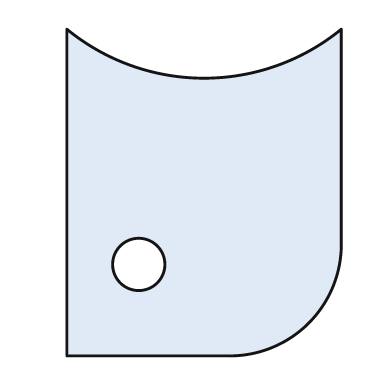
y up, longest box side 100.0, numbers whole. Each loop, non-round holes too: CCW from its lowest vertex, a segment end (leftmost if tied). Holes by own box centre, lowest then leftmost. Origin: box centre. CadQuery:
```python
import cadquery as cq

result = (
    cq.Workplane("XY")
    .moveTo(-42.0, -50.0)
    .lineTo(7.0, -50.0)
    .threePointArc((32.0, -40.0), (42.0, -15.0))
    .lineTo(42.0, 50.0)
    .threePointArc((0.0, 35.0), (-42.0, 50.0))
    .close()
    .moveTo(-20.0, -22.0)
    .circle(8.0)
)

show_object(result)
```